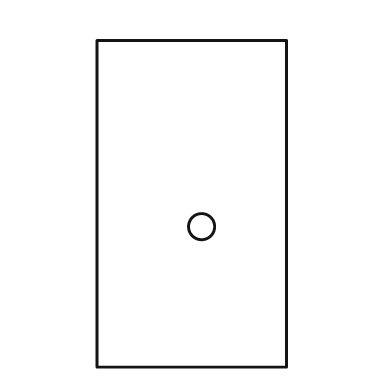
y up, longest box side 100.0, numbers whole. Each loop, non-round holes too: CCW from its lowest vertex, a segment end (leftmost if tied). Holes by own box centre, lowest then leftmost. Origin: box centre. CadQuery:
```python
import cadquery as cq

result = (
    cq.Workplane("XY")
    .moveTo(-29.0, -50.0)
    .lineTo(29.0, -50.0)
    .lineTo(29.0, 50.0)
    .lineTo(-29.0, 50.0)
    .close()
    .moveTo(3.0, -7.0)
    .circle(4.0)
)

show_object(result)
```